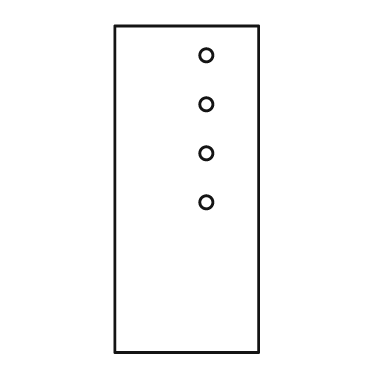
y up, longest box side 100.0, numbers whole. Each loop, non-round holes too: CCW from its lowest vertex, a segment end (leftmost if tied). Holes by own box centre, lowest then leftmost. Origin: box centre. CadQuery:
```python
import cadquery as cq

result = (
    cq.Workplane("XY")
    .moveTo(-22.0, -50.0)
    .lineTo(22.0, -50.0)
    .lineTo(22.0, 50.0)
    .lineTo(-22.0, 50.0)
    .close()
    .moveTo(6.0, -4.0)
    .circle(2.0)
    .moveTo(6.0, 11.0)
    .circle(2.0)
    .moveTo(6.0, 26.0)
    .circle(2.0)
    .moveTo(6.0, 41.0)
    .circle(2.0)
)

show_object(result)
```